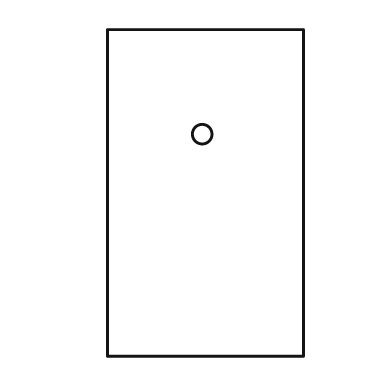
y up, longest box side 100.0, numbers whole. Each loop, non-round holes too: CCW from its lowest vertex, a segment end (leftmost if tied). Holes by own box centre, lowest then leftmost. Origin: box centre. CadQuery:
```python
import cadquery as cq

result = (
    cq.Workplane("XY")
    .moveTo(-30.0, -50.0)
    .lineTo(30.0, -50.0)
    .lineTo(30.0, 50.0)
    .lineTo(-30.0, 50.0)
    .close()
    .moveTo(-1.0, 18.0)
    .circle(3.0)
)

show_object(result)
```